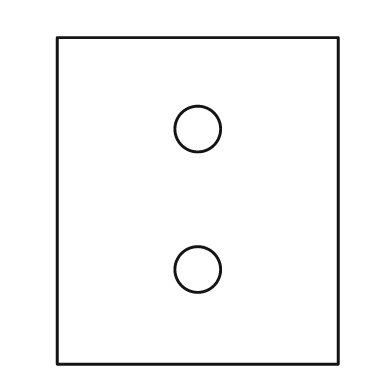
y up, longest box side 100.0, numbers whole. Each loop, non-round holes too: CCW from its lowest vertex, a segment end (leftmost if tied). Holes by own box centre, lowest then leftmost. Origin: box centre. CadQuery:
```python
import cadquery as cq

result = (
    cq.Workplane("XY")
    .moveTo(-43.0, -50.0)
    .lineTo(43.0, -50.0)
    .lineTo(43.0, 50.0)
    .lineTo(-43.0, 50.0)
    .close()
    .moveTo(0.0, -21.0)
    .circle(7.0)
    .moveTo(0.0, 22.0)
    .circle(7.0)
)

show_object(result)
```